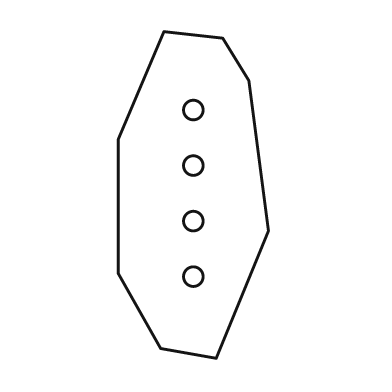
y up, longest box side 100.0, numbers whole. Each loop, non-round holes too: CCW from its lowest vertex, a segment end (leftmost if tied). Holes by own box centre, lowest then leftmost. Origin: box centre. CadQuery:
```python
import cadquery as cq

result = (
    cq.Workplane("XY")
    .moveTo(7.0, -50.0)
    .lineTo(23.0, -11.0)
    .lineTo(17.0, 35.0)
    .lineTo(9.0, 48.0)
    .lineTo(-9.0, 50.0)
    .lineTo(-23.0, 17.0)
    .lineTo(-23.0, -24.0)
    .lineTo(-10.0, -47.0)
    .close()
    .moveTo(0.0, -25.0)
    .circle(3.0)
    .moveTo(0.0, -8.0)
    .circle(3.0)
    .moveTo(0.0, 9.0)
    .circle(3.0)
    .moveTo(0.0, 26.0)
    .circle(3.0)
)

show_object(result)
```